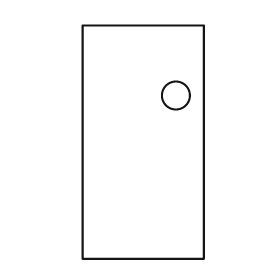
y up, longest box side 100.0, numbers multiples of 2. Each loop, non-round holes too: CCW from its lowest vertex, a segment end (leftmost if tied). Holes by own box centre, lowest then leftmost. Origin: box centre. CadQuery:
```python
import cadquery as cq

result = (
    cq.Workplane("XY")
    .moveTo(-26.0, -50.0)
    .lineTo(26.0, -50.0)
    .lineTo(26.0, 50.0)
    .lineTo(-26.0, 50.0)
    .close()
    .moveTo(14.0, 20.0)
    .circle(6.0)
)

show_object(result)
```